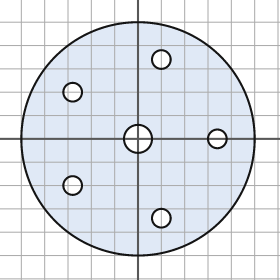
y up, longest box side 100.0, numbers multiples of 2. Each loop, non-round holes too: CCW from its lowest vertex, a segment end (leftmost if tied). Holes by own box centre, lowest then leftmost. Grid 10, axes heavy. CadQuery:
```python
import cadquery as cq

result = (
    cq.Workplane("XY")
    .moveTo(0.0, 0.0)
    .circle(50.0)
    .moveTo(10.0, -34.0)
    .circle(4.0)
    .moveTo(-28.0, -20.0)
    .circle(4.0)
    .moveTo(0.0, 0.0)
    .circle(6.0)
    .moveTo(34.0, 0.0)
    .circle(4.0)
    .moveTo(-28.0, 20.0)
    .circle(4.0)
    .moveTo(10.0, 34.0)
    .circle(4.0)
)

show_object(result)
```